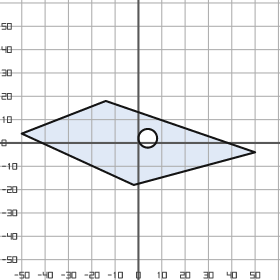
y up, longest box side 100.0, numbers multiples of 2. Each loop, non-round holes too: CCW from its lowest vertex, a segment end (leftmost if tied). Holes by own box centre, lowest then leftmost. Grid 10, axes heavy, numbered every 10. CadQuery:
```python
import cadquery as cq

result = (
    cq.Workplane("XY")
    .moveTo(-2.0, -18.0)
    .lineTo(50.0, -4.0)
    .lineTo(-14.0, 18.0)
    .lineTo(-50.0, 4.0)
    .close()
    .moveTo(4.0, 2.0)
    .circle(4.0)
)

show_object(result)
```